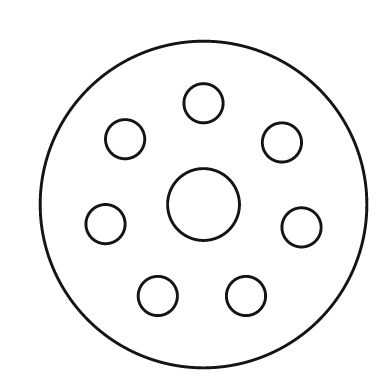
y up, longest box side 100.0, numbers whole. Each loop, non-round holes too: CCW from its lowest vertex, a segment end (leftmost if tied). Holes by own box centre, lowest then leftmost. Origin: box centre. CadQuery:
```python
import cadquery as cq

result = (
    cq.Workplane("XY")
    .moveTo(0.0, 0.0)
    .circle(50.0)
    .moveTo(-14.0, -28.0)
    .circle(6.0)
    .moveTo(13.0, -28.0)
    .circle(6.0)
    .moveTo(30.0, -7.0)
    .circle(6.0)
    .moveTo(-30.0, -6.0)
    .circle(6.0)
    .moveTo(0.0, 0.0)
    .circle(11.0)
    .moveTo(24.0, 19.0)
    .circle(6.0)
    .moveTo(-24.0, 20.0)
    .circle(6.0)
    .moveTo(0.0, 31.0)
    .circle(6.0)
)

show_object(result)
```